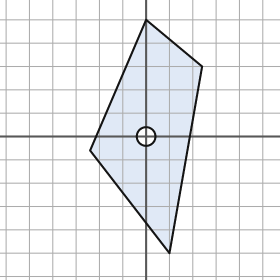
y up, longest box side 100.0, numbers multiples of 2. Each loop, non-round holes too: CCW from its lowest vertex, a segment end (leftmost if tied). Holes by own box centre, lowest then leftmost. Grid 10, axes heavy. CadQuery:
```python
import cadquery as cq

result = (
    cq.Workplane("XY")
    .moveTo(10.0, -50.0)
    .lineTo(24.0, 30.0)
    .lineTo(0.0, 50.0)
    .lineTo(-24.0, -6.0)
    .close()
    .moveTo(0.0, 0.0)
    .circle(4.0)
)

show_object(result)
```